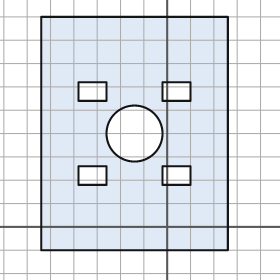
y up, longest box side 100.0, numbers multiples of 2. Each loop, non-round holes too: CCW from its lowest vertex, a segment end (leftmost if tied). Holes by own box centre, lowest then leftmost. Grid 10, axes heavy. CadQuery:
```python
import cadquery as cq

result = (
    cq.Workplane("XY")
    .moveTo(-54.0, -10.0)
    .lineTo(26.0, -10.0)
    .lineTo(26.0, 90.0)
    .lineTo(-54.0, 90.0)
    .close()
    .moveTo(-38.0, 18.0)
    .lineTo(-26.0, 18.0)
    .lineTo(-26.0, 26.0)
    .lineTo(-38.0, 26.0)
    .close()
    .moveTo(-2.0, 18.0)
    .lineTo(10.0, 18.0)
    .lineTo(10.0, 26.0)
    .lineTo(-2.0, 26.0)
    .close()
    .moveTo(-14.0, 40.0)
    .circle(12.0)
    .moveTo(-38.0, 54.0)
    .lineTo(-26.0, 54.0)
    .lineTo(-26.0, 62.0)
    .lineTo(-38.0, 62.0)
    .close()
    .moveTo(-2.0, 54.0)
    .lineTo(10.0, 54.0)
    .lineTo(10.0, 62.0)
    .lineTo(-2.0, 62.0)
    .close()
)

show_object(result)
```